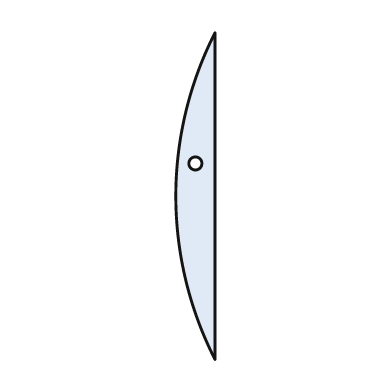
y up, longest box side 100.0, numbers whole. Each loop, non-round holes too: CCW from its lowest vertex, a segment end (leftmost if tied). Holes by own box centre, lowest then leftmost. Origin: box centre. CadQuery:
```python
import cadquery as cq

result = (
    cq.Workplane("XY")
    .moveTo(6.0, -50.0)
    .lineTo(6.0, 50.0)
    .threePointArc((-6.0, 0.0), (6.0, -50.0))
    .close()
    .moveTo(0.0, 10.0)
    .circle(2.0)
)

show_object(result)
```